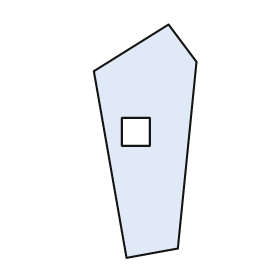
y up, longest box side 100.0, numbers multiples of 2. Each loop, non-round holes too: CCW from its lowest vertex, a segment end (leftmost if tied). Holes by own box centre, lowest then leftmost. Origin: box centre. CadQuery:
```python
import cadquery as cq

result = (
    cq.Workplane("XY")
    .moveTo(-8.0, -50.0)
    .lineTo(14.0, -46.0)
    .lineTo(22.0, 34.0)
    .lineTo(10.0, 50.0)
    .lineTo(-22.0, 30.0)
    .close()
    .moveTo(-10.0, -2.0)
    .lineTo(2.0, -2.0)
    .lineTo(2.0, 10.0)
    .lineTo(-10.0, 10.0)
    .close()
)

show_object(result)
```